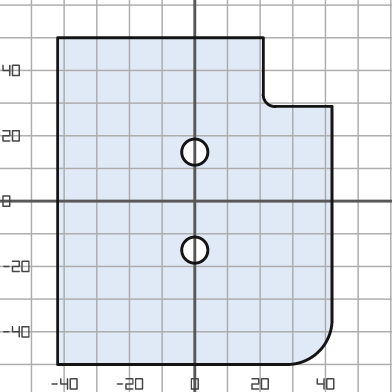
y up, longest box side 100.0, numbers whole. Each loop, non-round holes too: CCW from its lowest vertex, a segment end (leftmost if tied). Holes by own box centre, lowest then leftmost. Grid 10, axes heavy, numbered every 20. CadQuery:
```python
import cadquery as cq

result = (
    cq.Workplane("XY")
    .moveTo(-42.0, -50.0)
    .lineTo(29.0, -50.0)
    .threePointArc((38.0, -46.0), (42.0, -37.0))
    .lineTo(42.0, 29.0)
    .lineTo(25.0, 29.0)
    .threePointArc((22.0, 30.0), (21.0, 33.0))
    .lineTo(21.0, 50.0)
    .lineTo(-42.0, 50.0)
    .close()
    .moveTo(0.0, -15.0)
    .circle(4.0)
    .moveTo(0.0, 15.0)
    .circle(4.0)
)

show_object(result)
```